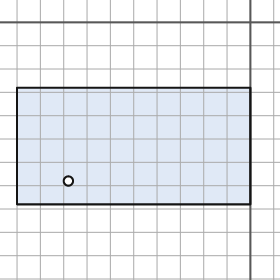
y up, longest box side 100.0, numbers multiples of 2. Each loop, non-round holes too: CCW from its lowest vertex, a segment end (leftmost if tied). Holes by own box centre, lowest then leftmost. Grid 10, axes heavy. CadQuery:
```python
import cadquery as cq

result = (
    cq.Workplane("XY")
    .moveTo(-100.0, -78.0)
    .lineTo(0.0, -78.0)
    .lineTo(0.0, -28.0)
    .lineTo(-100.0, -28.0)
    .close()
    .moveTo(-78.0, -68.0)
    .circle(2.0)
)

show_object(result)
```